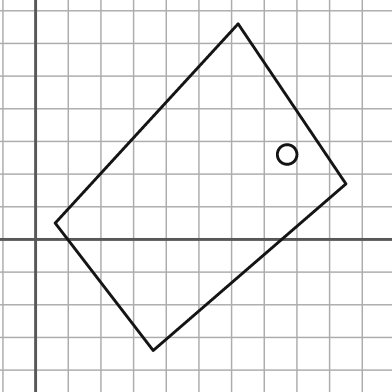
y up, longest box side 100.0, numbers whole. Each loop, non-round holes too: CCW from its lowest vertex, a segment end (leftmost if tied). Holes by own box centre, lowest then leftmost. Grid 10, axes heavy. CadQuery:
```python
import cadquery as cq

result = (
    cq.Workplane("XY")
    .moveTo(36.0, -34.0)
    .lineTo(95.0, 17.0)
    .lineTo(62.0, 66.0)
    .lineTo(6.0, 5.0)
    .close()
    .moveTo(77.0, 26.0)
    .circle(3.0)
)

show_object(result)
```